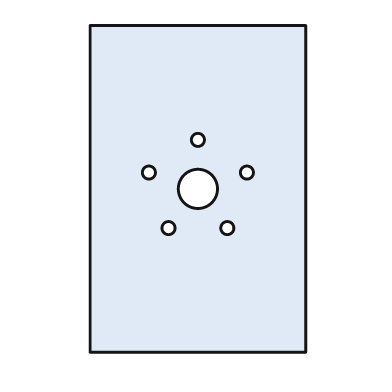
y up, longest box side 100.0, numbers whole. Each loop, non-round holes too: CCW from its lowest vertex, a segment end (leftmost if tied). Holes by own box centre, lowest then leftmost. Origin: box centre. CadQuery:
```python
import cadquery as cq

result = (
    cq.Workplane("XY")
    .moveTo(-33.0, -50.0)
    .lineTo(33.0, -50.0)
    .lineTo(33.0, 50.0)
    .lineTo(-33.0, 50.0)
    .close()
    .moveTo(-9.0, -12.0)
    .circle(2.0)
    .moveTo(9.0, -12.0)
    .circle(2.0)
    .moveTo(0.0, 0.0)
    .circle(6.0)
    .moveTo(-15.0, 5.0)
    .circle(2.0)
    .moveTo(15.0, 5.0)
    .circle(2.0)
    .moveTo(0.0, 15.0)
    .circle(2.0)
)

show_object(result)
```